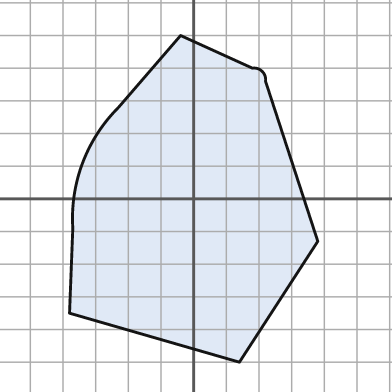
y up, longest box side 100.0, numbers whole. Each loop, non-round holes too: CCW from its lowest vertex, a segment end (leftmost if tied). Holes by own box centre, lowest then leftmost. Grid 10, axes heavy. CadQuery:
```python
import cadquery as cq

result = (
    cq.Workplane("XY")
    .moveTo(14.0, -50.0)
    .lineTo(38.0, -13.0)
    .lineTo(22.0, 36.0)
    .threePointArc((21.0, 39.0), (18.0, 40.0))
    .lineTo(-4.0, 50.0)
    .lineTo(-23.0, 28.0)
    .threePointArc((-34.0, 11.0), (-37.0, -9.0))
    .lineTo(-38.0, -35.0)
    .close()
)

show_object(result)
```